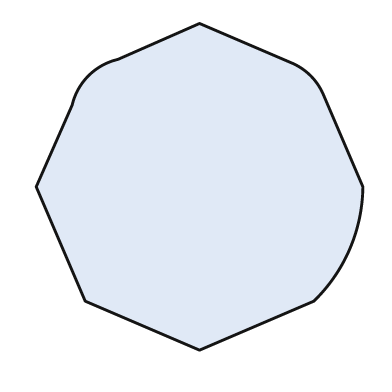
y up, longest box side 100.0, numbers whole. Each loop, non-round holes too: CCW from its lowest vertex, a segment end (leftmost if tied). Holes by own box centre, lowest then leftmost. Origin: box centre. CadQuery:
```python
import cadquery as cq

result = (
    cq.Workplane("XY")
    .moveTo(0.0, -50.0)
    .lineTo(35.0, -35.0)
    .threePointArc((46.0, -19.0), (50.0, 0.0))
    .lineTo(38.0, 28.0)
    .threePointArc((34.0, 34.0), (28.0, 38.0))
    .lineTo(0.0, 50.0)
    .lineTo(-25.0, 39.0)
    .threePointArc((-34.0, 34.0), (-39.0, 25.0))
    .lineTo(-50.0, 0.0)
    .lineTo(-35.0, -35.0)
    .close()
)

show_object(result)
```